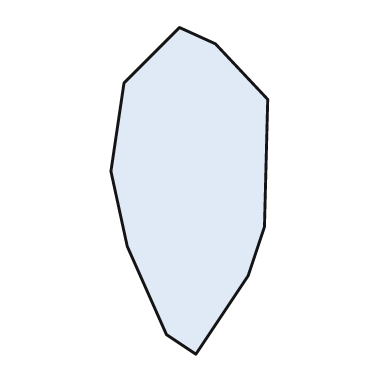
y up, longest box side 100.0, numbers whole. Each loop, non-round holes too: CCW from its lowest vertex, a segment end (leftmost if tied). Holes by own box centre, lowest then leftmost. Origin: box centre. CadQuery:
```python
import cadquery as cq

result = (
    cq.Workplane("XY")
    .moveTo(2.0, -50.0)
    .lineTo(18.0, -26.0)
    .lineTo(23.0, -11.0)
    .lineTo(24.0, 28.0)
    .lineTo(8.0, 45.0)
    .lineTo(-3.0, 50.0)
    .lineTo(-20.0, 33.0)
    .lineTo(-24.0, 6.0)
    .lineTo(-19.0, -17.0)
    .lineTo(-7.0, -44.0)
    .close()
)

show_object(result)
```